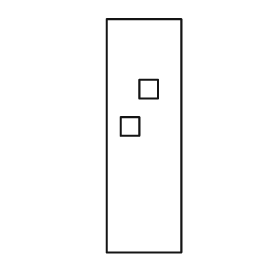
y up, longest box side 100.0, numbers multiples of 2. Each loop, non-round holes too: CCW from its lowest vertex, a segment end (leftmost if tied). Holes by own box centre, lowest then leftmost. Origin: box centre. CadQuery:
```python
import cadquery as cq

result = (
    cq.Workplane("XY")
    .moveTo(-16.0, -50.0)
    .lineTo(16.0, -50.0)
    .lineTo(16.0, 50.0)
    .lineTo(-16.0, 50.0)
    .close()
    .moveTo(-10.0, 0.0)
    .lineTo(-2.0, 0.0)
    .lineTo(-2.0, 8.0)
    .lineTo(-10.0, 8.0)
    .close()
    .moveTo(-2.0, 16.0)
    .lineTo(6.0, 16.0)
    .lineTo(6.0, 24.0)
    .lineTo(-2.0, 24.0)
    .close()
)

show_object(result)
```